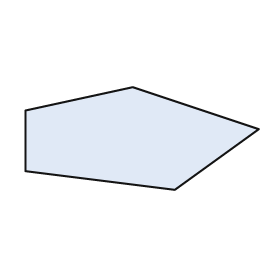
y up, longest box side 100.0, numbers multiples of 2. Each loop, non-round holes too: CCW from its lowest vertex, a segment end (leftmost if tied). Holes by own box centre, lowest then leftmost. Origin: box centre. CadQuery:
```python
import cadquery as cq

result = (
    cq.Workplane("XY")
    .moveTo(14.0, -22.0)
    .lineTo(50.0, 4.0)
    .lineTo(-4.0, 22.0)
    .lineTo(-50.0, 12.0)
    .lineTo(-50.0, -14.0)
    .close()
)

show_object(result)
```